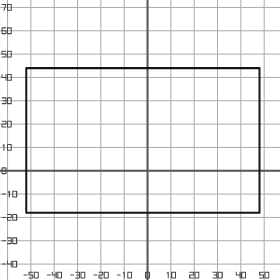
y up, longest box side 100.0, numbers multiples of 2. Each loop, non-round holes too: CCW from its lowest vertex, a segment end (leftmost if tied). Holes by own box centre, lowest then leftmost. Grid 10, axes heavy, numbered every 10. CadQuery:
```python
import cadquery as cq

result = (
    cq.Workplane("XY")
    .moveTo(-52.0, -18.0)
    .lineTo(48.0, -18.0)
    .lineTo(48.0, 44.0)
    .lineTo(-52.0, 44.0)
    .close()
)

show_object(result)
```